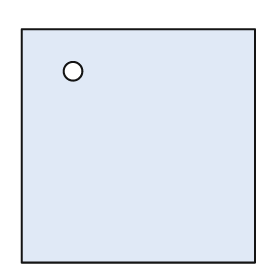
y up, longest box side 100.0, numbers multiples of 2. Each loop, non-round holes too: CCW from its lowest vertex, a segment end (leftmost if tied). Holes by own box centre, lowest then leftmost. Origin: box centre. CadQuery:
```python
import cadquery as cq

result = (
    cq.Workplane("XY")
    .moveTo(-50.0, -50.0)
    .lineTo(50.0, -50.0)
    .lineTo(50.0, 50.0)
    .lineTo(-50.0, 50.0)
    .close()
    .moveTo(-28.0, 32.0)
    .circle(4.0)
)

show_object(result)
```